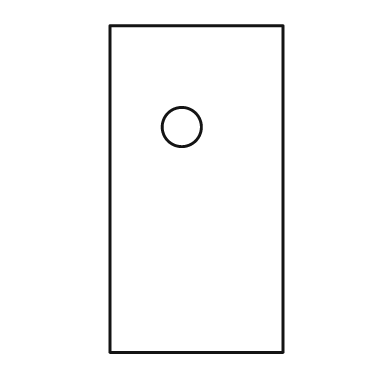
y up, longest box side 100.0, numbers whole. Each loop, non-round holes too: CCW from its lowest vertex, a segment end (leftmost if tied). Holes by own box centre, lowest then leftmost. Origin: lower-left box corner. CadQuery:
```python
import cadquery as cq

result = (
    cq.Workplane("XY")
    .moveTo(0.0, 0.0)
    .lineTo(53.0, 0.0)
    .lineTo(53.0, 100.0)
    .lineTo(0.0, 100.0)
    .close()
    .moveTo(22.0, 69.0)
    .circle(6.0)
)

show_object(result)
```